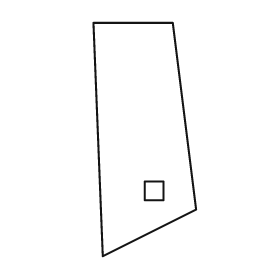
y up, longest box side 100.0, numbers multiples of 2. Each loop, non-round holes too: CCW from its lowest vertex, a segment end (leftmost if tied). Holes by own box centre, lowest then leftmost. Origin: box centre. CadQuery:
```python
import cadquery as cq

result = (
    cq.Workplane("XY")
    .moveTo(-18.0, -50.0)
    .lineTo(22.0, -30.0)
    .lineTo(12.0, 50.0)
    .lineTo(-22.0, 50.0)
    .close()
    .moveTo(0.0, -26.0)
    .lineTo(8.0, -26.0)
    .lineTo(8.0, -18.0)
    .lineTo(0.0, -18.0)
    .close()
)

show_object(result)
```